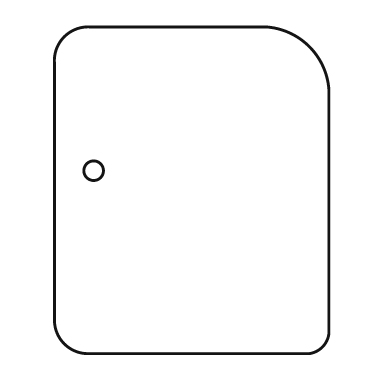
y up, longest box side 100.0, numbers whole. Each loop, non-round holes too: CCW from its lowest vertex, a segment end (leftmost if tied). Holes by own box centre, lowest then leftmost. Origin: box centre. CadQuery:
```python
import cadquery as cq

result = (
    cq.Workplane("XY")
    .moveTo(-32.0, -50.0)
    .lineTo(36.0, -50.0)
    .threePointArc((40.0, -48.0), (42.0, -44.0))
    .lineTo(42.0, 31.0)
    .threePointArc((36.0, 44.0), (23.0, 50.0))
    .lineTo(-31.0, 50.0)
    .threePointArc((-39.0, 47.0), (-42.0, 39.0))
    .lineTo(-42.0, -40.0)
    .threePointArc((-39.0, -47.0), (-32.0, -50.0))
    .close()
    .moveTo(-30.0, 6.0)
    .circle(3.0)
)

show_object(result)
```